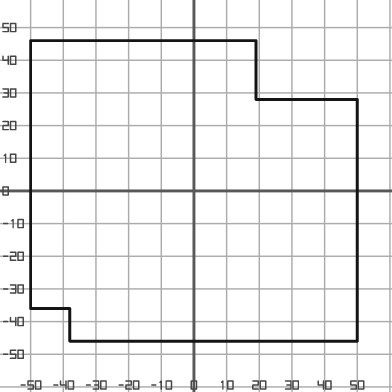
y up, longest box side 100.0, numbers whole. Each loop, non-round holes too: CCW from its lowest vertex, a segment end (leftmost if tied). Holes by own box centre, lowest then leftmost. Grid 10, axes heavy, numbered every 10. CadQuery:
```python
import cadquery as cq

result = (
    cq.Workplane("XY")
    .moveTo(-38.0, -46.0)
    .lineTo(50.0, -46.0)
    .lineTo(50.0, 28.0)
    .lineTo(19.0, 28.0)
    .lineTo(19.0, 46.0)
    .lineTo(-50.0, 46.0)
    .lineTo(-50.0, -36.0)
    .lineTo(-38.0, -36.0)
    .close()
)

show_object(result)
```